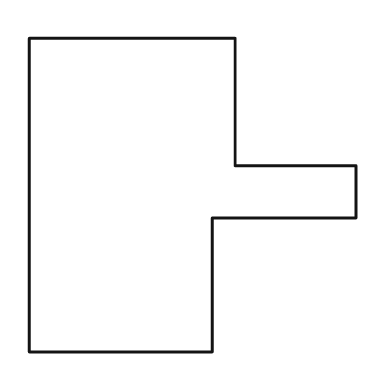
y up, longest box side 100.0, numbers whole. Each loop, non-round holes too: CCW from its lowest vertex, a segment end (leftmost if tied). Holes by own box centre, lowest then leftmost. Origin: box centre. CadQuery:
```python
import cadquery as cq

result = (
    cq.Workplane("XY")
    .moveTo(-50.0, -48.0)
    .lineTo(6.0, -48.0)
    .lineTo(6.0, -7.0)
    .lineTo(50.0, -7.0)
    .lineTo(50.0, 9.0)
    .lineTo(13.0, 9.0)
    .lineTo(13.0, 48.0)
    .lineTo(-50.0, 48.0)
    .close()
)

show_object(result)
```